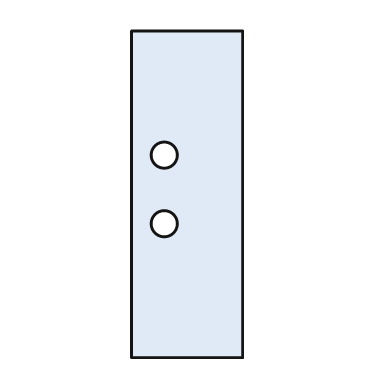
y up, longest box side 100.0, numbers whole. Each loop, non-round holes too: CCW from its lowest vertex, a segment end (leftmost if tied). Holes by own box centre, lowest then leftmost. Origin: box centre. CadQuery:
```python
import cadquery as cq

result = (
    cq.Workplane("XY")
    .moveTo(-17.0, -50.0)
    .lineTo(17.0, -50.0)
    .lineTo(17.0, 50.0)
    .lineTo(-17.0, 50.0)
    .close()
    .moveTo(-7.0, -9.0)
    .circle(4.0)
    .moveTo(-7.0, 12.0)
    .circle(4.0)
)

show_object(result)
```